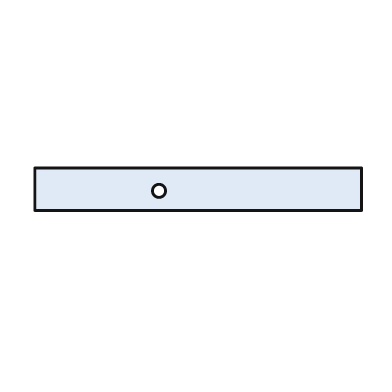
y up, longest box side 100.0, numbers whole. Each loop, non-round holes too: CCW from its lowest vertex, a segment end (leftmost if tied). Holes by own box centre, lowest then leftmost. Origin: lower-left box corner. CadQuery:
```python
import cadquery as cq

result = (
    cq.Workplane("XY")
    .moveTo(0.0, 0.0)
    .lineTo(100.0, 0.0)
    .lineTo(100.0, 13.0)
    .lineTo(0.0, 13.0)
    .close()
    .moveTo(38.0, 6.0)
    .circle(2.0)
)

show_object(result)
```